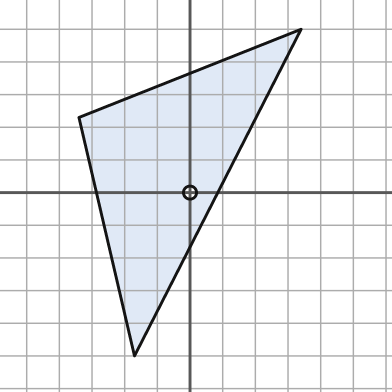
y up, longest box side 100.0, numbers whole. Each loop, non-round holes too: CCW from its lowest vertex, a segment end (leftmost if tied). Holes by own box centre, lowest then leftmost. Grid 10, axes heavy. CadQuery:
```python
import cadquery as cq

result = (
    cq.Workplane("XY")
    .moveTo(-17.0, -50.0)
    .lineTo(34.0, 50.0)
    .lineTo(-34.0, 23.0)
    .close()
    .moveTo(0.0, 0.0)
    .circle(2.0)
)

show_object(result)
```